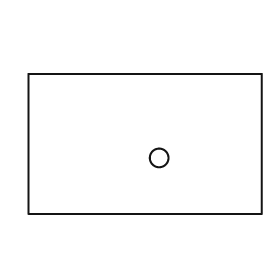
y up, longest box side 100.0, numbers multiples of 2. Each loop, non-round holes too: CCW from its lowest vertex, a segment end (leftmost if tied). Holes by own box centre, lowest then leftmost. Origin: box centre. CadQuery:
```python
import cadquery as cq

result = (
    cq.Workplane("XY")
    .moveTo(-50.0, -30.0)
    .lineTo(50.0, -30.0)
    .lineTo(50.0, 30.0)
    .lineTo(-50.0, 30.0)
    .close()
    .moveTo(6.0, -6.0)
    .circle(4.0)
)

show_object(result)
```